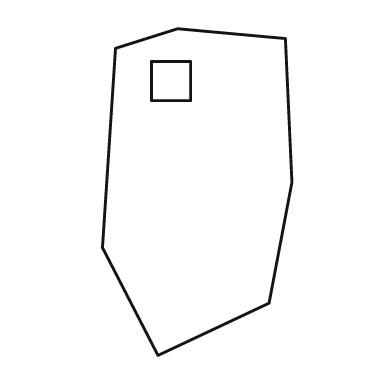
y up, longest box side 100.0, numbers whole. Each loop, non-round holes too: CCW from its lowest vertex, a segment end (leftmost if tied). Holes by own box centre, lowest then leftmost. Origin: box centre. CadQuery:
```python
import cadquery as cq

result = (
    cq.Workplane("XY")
    .moveTo(-12.0, -50.0)
    .lineTo(22.0, -34.0)
    .lineTo(29.0, 3.0)
    .lineTo(27.0, 47.0)
    .lineTo(-6.0, 50.0)
    .lineTo(-25.0, 44.0)
    .lineTo(-29.0, -17.0)
    .close()
    .moveTo(-14.0, 28.0)
    .lineTo(-2.0, 28.0)
    .lineTo(-2.0, 40.0)
    .lineTo(-14.0, 40.0)
    .close()
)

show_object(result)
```